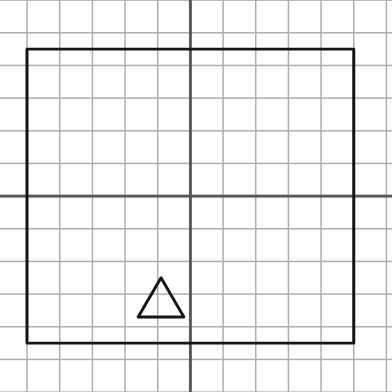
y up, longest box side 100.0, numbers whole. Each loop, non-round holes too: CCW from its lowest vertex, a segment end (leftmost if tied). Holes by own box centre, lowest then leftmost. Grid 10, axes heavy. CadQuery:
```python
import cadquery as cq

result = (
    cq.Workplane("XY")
    .moveTo(-50.0, -45.0)
    .lineTo(50.0, -45.0)
    .lineTo(50.0, 45.0)
    .lineTo(-50.0, 45.0)
    .close()
    .moveTo(-16.0, -37.0)
    .lineTo(-2.0, -37.0)
    .lineTo(-9.0, -25.0)
    .close()
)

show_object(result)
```